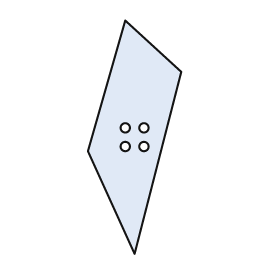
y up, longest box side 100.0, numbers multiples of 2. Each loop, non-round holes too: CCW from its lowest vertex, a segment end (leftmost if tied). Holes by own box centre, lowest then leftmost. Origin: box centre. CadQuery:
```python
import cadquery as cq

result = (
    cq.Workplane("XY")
    .moveTo(0.0, -50.0)
    .lineTo(20.0, 28.0)
    .lineTo(-4.0, 50.0)
    .lineTo(-20.0, -6.0)
    .close()
    .moveTo(-4.0, -4.0)
    .circle(2.0)
    .moveTo(4.0, -4.0)
    .circle(2.0)
    .moveTo(-4.0, 4.0)
    .circle(2.0)
    .moveTo(4.0, 4.0)
    .circle(2.0)
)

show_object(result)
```